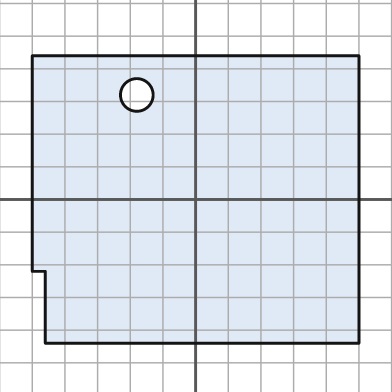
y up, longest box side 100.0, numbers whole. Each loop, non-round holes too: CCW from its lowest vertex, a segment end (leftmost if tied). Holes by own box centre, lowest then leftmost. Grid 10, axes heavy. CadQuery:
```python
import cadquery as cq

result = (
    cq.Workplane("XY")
    .moveTo(-46.0, -44.0)
    .lineTo(50.0, -44.0)
    .lineTo(50.0, 44.0)
    .lineTo(-50.0, 44.0)
    .lineTo(-50.0, -22.0)
    .lineTo(-46.0, -22.0)
    .close()
    .moveTo(-18.0, 32.0)
    .circle(5.0)
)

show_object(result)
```